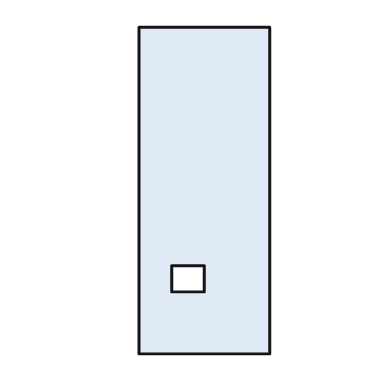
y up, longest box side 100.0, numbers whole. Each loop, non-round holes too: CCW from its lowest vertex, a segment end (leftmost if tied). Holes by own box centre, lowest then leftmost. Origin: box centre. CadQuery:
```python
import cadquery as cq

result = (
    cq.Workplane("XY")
    .moveTo(-20.0, -50.0)
    .lineTo(20.0, -50.0)
    .lineTo(20.0, 50.0)
    .lineTo(-20.0, 50.0)
    .close()
    .moveTo(-10.0, -31.0)
    .lineTo(0.0, -31.0)
    .lineTo(0.0, -23.0)
    .lineTo(-10.0, -23.0)
    .close()
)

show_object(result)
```